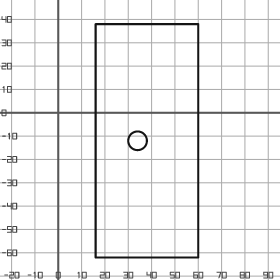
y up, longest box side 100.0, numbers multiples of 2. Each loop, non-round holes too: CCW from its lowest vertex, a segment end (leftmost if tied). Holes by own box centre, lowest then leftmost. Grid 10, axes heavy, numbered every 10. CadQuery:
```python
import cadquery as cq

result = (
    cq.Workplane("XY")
    .moveTo(16.0, -62.0)
    .lineTo(60.0, -62.0)
    .lineTo(60.0, 38.0)
    .lineTo(16.0, 38.0)
    .close()
    .moveTo(34.0, -12.0)
    .circle(4.0)
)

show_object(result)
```